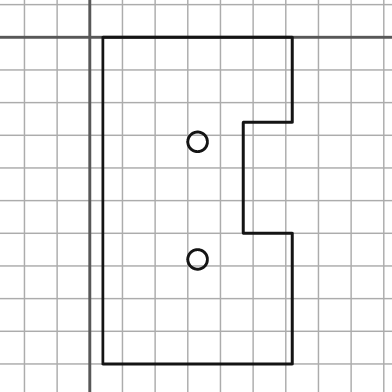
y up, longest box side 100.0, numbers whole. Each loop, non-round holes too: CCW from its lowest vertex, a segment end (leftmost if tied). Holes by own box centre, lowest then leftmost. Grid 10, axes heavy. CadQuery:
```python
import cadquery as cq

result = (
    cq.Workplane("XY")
    .moveTo(4.0, -100.0)
    .lineTo(62.0, -100.0)
    .lineTo(62.0, -60.0)
    .lineTo(47.0, -60.0)
    .lineTo(47.0, -26.0)
    .lineTo(62.0, -26.0)
    .lineTo(62.0, 0.0)
    .lineTo(4.0, 0.0)
    .close()
    .moveTo(33.0, -68.0)
    .circle(3.0)
    .moveTo(33.0, -32.0)
    .circle(3.0)
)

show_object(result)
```